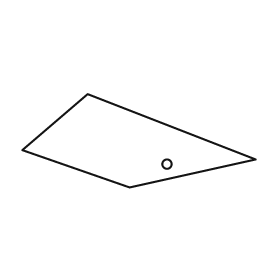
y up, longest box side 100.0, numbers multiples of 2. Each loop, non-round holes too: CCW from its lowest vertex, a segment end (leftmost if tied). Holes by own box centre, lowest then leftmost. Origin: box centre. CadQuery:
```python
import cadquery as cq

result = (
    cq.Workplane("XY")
    .moveTo(-4.0, -20.0)
    .lineTo(50.0, -8.0)
    .lineTo(-22.0, 20.0)
    .lineTo(-50.0, -4.0)
    .close()
    .moveTo(12.0, -10.0)
    .circle(2.0)
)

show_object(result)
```